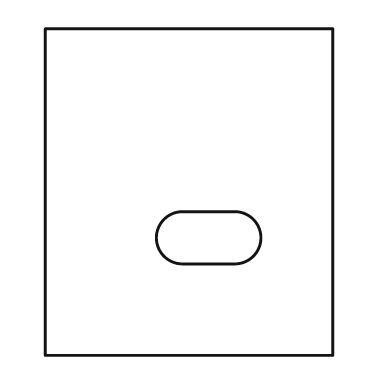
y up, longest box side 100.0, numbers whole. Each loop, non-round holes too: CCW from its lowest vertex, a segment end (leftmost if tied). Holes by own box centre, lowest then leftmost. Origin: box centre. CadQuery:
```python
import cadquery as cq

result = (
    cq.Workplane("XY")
    .moveTo(-44.0, -50.0)
    .lineTo(44.0, -50.0)
    .lineTo(44.0, 50.0)
    .lineTo(-44.0, 50.0)
    .close()
    .moveTo(-2.0, -22.0)
    .lineTo(14.0, -22.0)
    .threePointArc((22.0, -14.0), (14.0, -6.0))
    .lineTo(-2.0, -6.0)
    .threePointArc((-10.0, -14.0), (-2.0, -22.0))
    .close()
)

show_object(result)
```